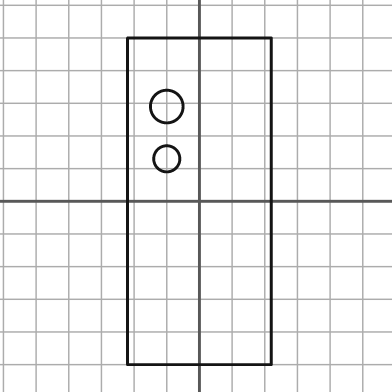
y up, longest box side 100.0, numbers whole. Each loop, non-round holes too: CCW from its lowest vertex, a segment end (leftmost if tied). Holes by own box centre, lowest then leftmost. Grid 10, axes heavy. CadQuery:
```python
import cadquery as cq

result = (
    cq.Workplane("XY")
    .moveTo(-22.0, -50.0)
    .lineTo(22.0, -50.0)
    .lineTo(22.0, 50.0)
    .lineTo(-22.0, 50.0)
    .close()
    .moveTo(-10.0, 13.0)
    .circle(4.0)
    .moveTo(-10.0, 29.0)
    .circle(5.0)
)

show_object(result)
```